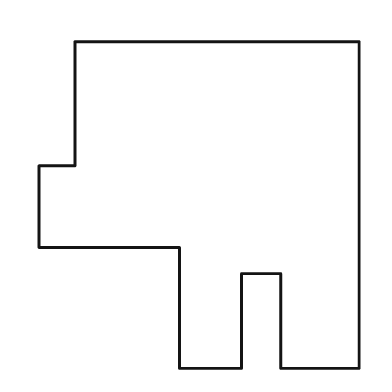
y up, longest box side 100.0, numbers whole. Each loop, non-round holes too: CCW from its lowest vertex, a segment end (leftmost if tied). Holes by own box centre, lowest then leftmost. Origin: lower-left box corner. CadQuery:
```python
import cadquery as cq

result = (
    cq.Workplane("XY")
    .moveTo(43.0, 0.0)
    .lineTo(62.0, 0.0)
    .lineTo(62.0, 29.0)
    .lineTo(74.0, 29.0)
    .lineTo(74.0, 0.0)
    .lineTo(98.0, 0.0)
    .lineTo(98.0, 100.0)
    .lineTo(11.0, 100.0)
    .lineTo(11.0, 62.0)
    .lineTo(0.0, 62.0)
    .lineTo(0.0, 37.0)
    .lineTo(43.0, 37.0)
    .close()
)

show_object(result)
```